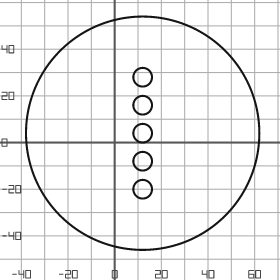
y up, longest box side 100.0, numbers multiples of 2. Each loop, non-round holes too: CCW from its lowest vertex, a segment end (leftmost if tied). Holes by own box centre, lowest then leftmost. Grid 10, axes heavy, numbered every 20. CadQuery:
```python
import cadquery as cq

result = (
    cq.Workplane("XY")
    .moveTo(12.0, 4.0)
    .circle(50.0)
    .moveTo(12.0, -20.0)
    .circle(4.0)
    .moveTo(12.0, -8.0)
    .circle(4.0)
    .moveTo(12.0, 4.0)
    .circle(4.0)
    .moveTo(12.0, 16.0)
    .circle(4.0)
    .moveTo(12.0, 28.0)
    .circle(4.0)
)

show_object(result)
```